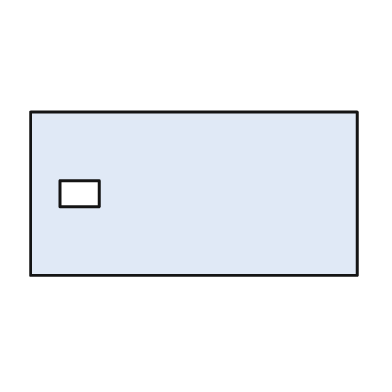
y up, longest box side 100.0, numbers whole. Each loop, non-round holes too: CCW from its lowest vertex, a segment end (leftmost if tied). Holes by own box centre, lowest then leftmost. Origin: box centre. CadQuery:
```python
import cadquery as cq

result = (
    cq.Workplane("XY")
    .moveTo(-50.0, -25.0)
    .lineTo(50.0, -25.0)
    .lineTo(50.0, 25.0)
    .lineTo(-50.0, 25.0)
    .close()
    .moveTo(-41.0, -4.0)
    .lineTo(-29.0, -4.0)
    .lineTo(-29.0, 4.0)
    .lineTo(-41.0, 4.0)
    .close()
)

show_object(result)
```